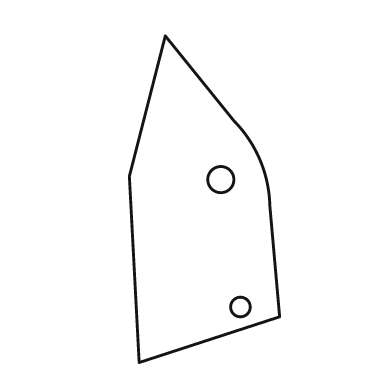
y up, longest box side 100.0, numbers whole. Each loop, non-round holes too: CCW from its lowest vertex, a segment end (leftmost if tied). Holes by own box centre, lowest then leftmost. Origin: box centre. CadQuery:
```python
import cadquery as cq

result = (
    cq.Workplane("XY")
    .moveTo(-20.0, -50.0)
    .lineTo(23.0, -36.0)
    .lineTo(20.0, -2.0)
    .threePointArc((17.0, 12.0), (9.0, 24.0))
    .lineTo(-12.0, 50.0)
    .lineTo(-23.0, 7.0)
    .close()
    .moveTo(11.0, -33.0)
    .circle(3.0)
    .moveTo(5.0, 6.0)
    .circle(4.0)
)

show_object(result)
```